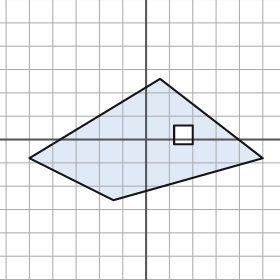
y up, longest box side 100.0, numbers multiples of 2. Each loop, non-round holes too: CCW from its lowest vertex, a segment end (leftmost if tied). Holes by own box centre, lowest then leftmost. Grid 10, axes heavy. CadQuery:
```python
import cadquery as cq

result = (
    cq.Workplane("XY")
    .moveTo(-14.0, -26.0)
    .lineTo(50.0, -8.0)
    .lineTo(6.0, 26.0)
    .lineTo(-50.0, -8.0)
    .close()
    .moveTo(12.0, -2.0)
    .lineTo(20.0, -2.0)
    .lineTo(20.0, 6.0)
    .lineTo(12.0, 6.0)
    .close()
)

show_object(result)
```